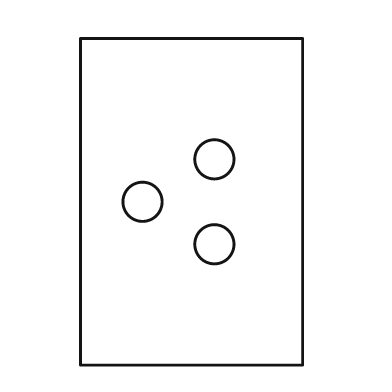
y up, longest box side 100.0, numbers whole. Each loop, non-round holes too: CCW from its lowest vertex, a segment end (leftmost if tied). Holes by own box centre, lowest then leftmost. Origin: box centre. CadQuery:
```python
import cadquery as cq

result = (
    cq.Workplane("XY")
    .moveTo(-34.0, -50.0)
    .lineTo(34.0, -50.0)
    .lineTo(34.0, 50.0)
    .lineTo(-34.0, 50.0)
    .close()
    .moveTo(7.0, -13.0)
    .circle(6.0)
    .moveTo(-15.0, 0.0)
    .circle(6.0)
    .moveTo(7.0, 13.0)
    .circle(6.0)
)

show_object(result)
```